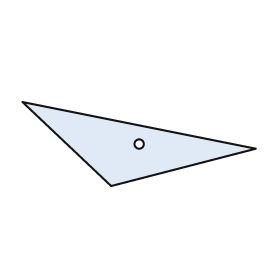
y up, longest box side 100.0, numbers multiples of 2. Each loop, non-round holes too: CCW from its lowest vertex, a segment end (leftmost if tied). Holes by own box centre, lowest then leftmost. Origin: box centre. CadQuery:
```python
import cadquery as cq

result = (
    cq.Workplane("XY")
    .moveTo(-12.0, -18.0)
    .lineTo(50.0, -2.0)
    .lineTo(-50.0, 18.0)
    .close()
    .moveTo(0.0, 0.0)
    .circle(2.0)
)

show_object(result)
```